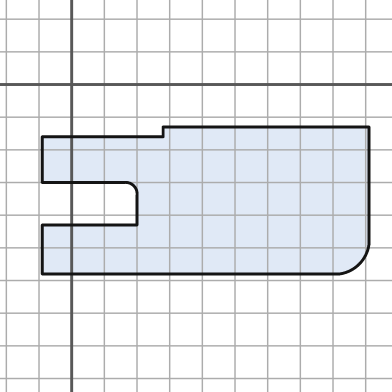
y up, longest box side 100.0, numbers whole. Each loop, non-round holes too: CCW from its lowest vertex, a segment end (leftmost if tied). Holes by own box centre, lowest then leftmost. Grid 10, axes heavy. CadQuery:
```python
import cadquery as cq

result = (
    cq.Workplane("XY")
    .moveTo(-9.0, -58.0)
    .lineTo(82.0, -58.0)
    .threePointArc((88.0, -55.0), (91.0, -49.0))
    .lineTo(91.0, -13.0)
    .lineTo(28.0, -13.0)
    .lineTo(28.0, -16.0)
    .lineTo(-9.0, -16.0)
    .lineTo(-9.0, -30.0)
    .lineTo(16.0, -30.0)
    .threePointArc((19.0, -31.0), (20.0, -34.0))
    .lineTo(20.0, -43.0)
    .lineTo(-9.0, -43.0)
    .close()
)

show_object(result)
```